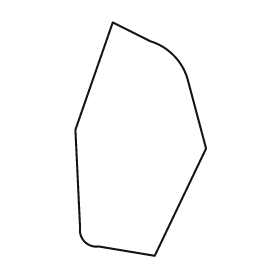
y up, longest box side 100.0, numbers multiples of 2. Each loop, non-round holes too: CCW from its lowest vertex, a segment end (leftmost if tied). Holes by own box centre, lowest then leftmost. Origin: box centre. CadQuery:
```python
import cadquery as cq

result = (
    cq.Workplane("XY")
    .moveTo(6.0, -50.0)
    .lineTo(28.0, -4.0)
    .lineTo(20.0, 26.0)
    .threePointArc((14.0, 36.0), (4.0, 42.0))
    .lineTo(-12.0, 50.0)
    .lineTo(-28.0, 4.0)
    .lineTo(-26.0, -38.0)
    .threePointArc((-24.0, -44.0), (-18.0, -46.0))
    .close()
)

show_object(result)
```